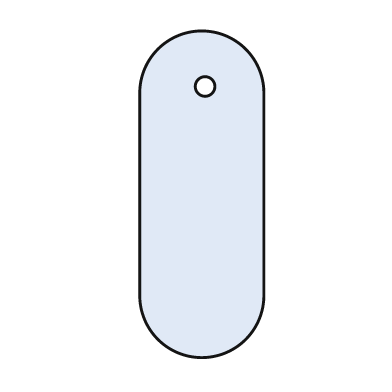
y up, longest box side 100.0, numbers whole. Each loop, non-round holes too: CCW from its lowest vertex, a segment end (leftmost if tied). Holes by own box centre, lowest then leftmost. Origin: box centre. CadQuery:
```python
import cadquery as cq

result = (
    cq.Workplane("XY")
    .moveTo(-19.0, -31.0)
    .threePointArc((0.0, -50.0), (19.0, -31.0))
    .lineTo(19.0, 31.0)
    .threePointArc((0.0, 50.0), (-19.0, 31.0))
    .close()
    .moveTo(1.0, 33.0)
    .circle(3.0)
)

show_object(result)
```